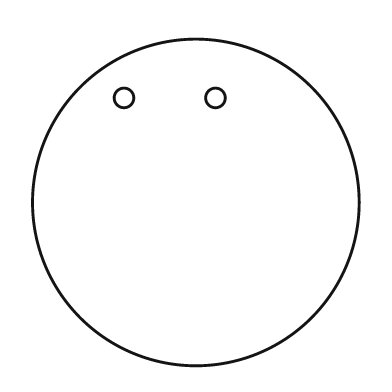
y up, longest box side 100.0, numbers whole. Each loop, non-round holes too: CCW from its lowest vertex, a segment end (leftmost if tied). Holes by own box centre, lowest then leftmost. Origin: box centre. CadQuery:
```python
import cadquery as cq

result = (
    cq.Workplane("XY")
    .moveTo(0.0, 0.0)
    .circle(50.0)
    .moveTo(-22.0, 32.0)
    .circle(3.0)
    .moveTo(6.0, 32.0)
    .circle(3.0)
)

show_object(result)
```